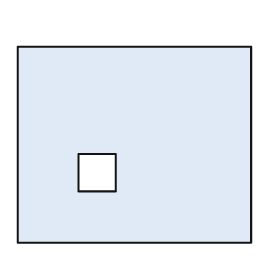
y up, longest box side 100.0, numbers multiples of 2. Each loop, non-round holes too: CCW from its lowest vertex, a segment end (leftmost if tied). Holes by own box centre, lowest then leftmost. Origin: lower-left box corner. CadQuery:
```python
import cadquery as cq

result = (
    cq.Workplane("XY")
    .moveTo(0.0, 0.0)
    .lineTo(100.0, 0.0)
    .lineTo(100.0, 84.0)
    .lineTo(0.0, 84.0)
    .close()
    .moveTo(26.0, 22.0)
    .lineTo(42.0, 22.0)
    .lineTo(42.0, 38.0)
    .lineTo(26.0, 38.0)
    .close()
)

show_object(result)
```